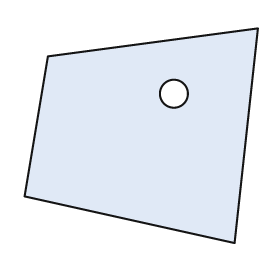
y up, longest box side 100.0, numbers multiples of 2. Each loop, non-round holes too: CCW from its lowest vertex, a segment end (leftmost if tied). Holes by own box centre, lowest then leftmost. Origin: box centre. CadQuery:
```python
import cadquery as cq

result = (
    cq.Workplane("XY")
    .moveTo(40.0, -46.0)
    .lineTo(50.0, 46.0)
    .lineTo(-40.0, 34.0)
    .lineTo(-50.0, -26.0)
    .close()
    .moveTo(14.0, 18.0)
    .circle(6.0)
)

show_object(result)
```